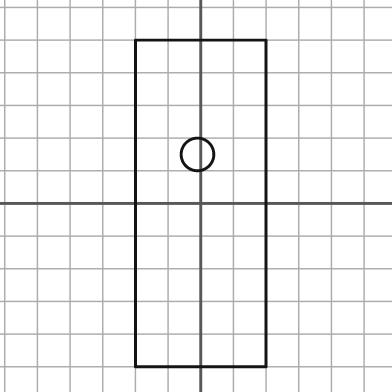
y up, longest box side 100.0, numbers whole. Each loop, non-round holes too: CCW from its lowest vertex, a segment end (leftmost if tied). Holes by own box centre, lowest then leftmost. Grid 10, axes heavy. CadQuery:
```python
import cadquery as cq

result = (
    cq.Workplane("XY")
    .moveTo(-20.0, -50.0)
    .lineTo(20.0, -50.0)
    .lineTo(20.0, 50.0)
    .lineTo(-20.0, 50.0)
    .close()
    .moveTo(-1.0, 15.0)
    .circle(5.0)
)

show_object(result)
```